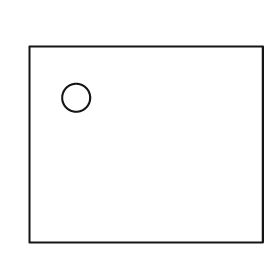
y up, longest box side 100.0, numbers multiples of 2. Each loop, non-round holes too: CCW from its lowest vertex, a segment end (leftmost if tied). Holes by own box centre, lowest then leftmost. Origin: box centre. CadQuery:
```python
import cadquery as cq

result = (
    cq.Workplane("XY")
    .moveTo(-50.0, -42.0)
    .lineTo(50.0, -42.0)
    .lineTo(50.0, 42.0)
    .lineTo(-50.0, 42.0)
    .close()
    .moveTo(-30.0, 20.0)
    .circle(6.0)
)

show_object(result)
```